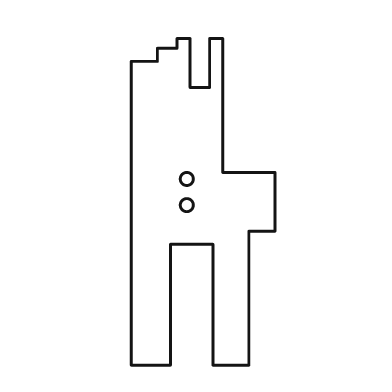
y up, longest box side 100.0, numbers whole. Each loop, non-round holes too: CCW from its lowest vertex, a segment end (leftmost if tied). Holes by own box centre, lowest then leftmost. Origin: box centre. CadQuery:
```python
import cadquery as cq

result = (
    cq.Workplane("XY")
    .moveTo(-22.0, -50.0)
    .lineTo(-10.0, -50.0)
    .lineTo(-10.0, -13.0)
    .lineTo(3.0, -13.0)
    .lineTo(3.0, -50.0)
    .lineTo(14.0, -50.0)
    .lineTo(14.0, -9.0)
    .lineTo(22.0, -9.0)
    .lineTo(22.0, 9.0)
    .lineTo(6.0, 9.0)
    .lineTo(6.0, 50.0)
    .lineTo(2.0, 50.0)
    .lineTo(2.0, 35.0)
    .lineTo(-4.0, 35.0)
    .lineTo(-4.0, 50.0)
    .lineTo(-8.0, 50.0)
    .lineTo(-8.0, 47.0)
    .lineTo(-14.0, 47.0)
    .lineTo(-14.0, 43.0)
    .lineTo(-22.0, 43.0)
    .close()
    .moveTo(-5.0, -1.0)
    .circle(2.0)
    .moveTo(-5.0, 7.0)
    .circle(2.0)
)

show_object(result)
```